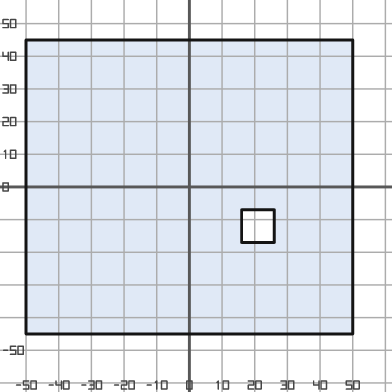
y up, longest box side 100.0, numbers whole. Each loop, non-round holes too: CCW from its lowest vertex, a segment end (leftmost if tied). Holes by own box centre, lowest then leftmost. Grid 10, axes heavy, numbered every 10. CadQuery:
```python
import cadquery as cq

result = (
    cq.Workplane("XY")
    .moveTo(-50.0, -45.0)
    .lineTo(50.0, -45.0)
    .lineTo(50.0, 45.0)
    .lineTo(-50.0, 45.0)
    .close()
    .moveTo(16.0, -17.0)
    .lineTo(26.0, -17.0)
    .lineTo(26.0, -7.0)
    .lineTo(16.0, -7.0)
    .close()
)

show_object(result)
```